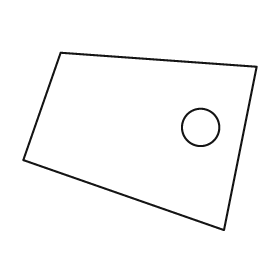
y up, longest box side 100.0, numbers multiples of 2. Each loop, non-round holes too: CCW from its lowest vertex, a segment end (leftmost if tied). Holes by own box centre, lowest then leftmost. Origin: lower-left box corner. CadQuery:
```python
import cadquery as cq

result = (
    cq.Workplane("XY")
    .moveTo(86.0, 0.0)
    .lineTo(100.0, 70.0)
    .lineTo(16.0, 76.0)
    .lineTo(0.0, 30.0)
    .close()
    .moveTo(76.0, 44.0)
    .circle(8.0)
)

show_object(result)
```